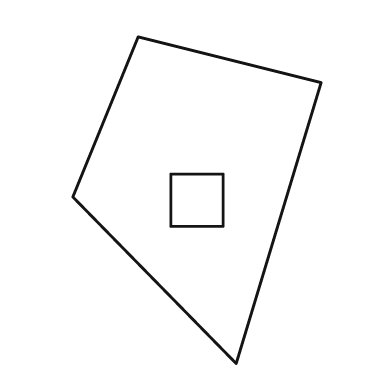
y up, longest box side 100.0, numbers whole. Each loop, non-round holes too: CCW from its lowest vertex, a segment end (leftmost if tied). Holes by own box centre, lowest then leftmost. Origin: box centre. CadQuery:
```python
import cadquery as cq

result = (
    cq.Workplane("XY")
    .moveTo(12.0, -50.0)
    .lineTo(38.0, 36.0)
    .lineTo(-18.0, 50.0)
    .lineTo(-38.0, 1.0)
    .close()
    .moveTo(-8.0, -8.0)
    .lineTo(8.0, -8.0)
    .lineTo(8.0, 8.0)
    .lineTo(-8.0, 8.0)
    .close()
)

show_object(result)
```